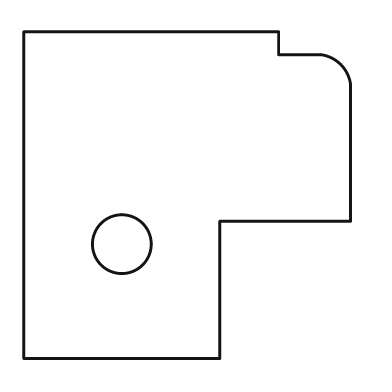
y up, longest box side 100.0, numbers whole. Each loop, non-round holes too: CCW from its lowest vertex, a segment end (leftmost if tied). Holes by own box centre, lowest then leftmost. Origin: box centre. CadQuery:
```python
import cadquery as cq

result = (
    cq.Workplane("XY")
    .moveTo(-50.0, -50.0)
    .lineTo(10.0, -50.0)
    .lineTo(10.0, -8.0)
    .lineTo(50.0, -8.0)
    .lineTo(50.0, 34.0)
    .threePointArc((47.0, 40.0), (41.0, 43.0))
    .lineTo(28.0, 43.0)
    .lineTo(28.0, 50.0)
    .lineTo(-50.0, 50.0)
    .close()
    .moveTo(-20.0, -15.0)
    .circle(9.0)
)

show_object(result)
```